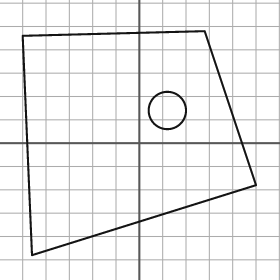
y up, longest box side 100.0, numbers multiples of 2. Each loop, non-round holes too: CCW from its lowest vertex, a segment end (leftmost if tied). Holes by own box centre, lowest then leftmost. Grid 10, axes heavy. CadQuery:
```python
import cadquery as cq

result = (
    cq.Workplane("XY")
    .moveTo(-46.0, -48.0)
    .lineTo(50.0, -18.0)
    .lineTo(28.0, 48.0)
    .lineTo(-50.0, 46.0)
    .close()
    .moveTo(12.0, 14.0)
    .circle(8.0)
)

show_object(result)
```